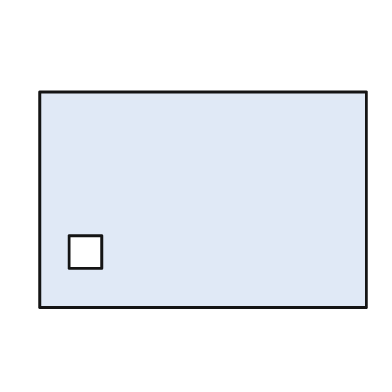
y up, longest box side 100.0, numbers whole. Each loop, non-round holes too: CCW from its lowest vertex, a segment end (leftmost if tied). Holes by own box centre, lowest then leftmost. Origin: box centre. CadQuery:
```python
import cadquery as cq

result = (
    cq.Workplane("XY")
    .moveTo(-50.0, -33.0)
    .lineTo(50.0, -33.0)
    .lineTo(50.0, 33.0)
    .lineTo(-50.0, 33.0)
    .close()
    .moveTo(-41.0, -21.0)
    .lineTo(-31.0, -21.0)
    .lineTo(-31.0, -11.0)
    .lineTo(-41.0, -11.0)
    .close()
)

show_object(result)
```